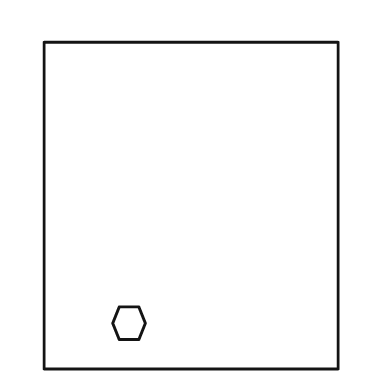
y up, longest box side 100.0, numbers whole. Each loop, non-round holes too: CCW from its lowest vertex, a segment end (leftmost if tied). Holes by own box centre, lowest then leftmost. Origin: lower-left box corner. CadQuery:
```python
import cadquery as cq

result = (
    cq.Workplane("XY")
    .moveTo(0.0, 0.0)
    .lineTo(90.0, 0.0)
    .lineTo(90.0, 100.0)
    .lineTo(0.0, 100.0)
    .close()
    .moveTo(23.0, 9.0)
    .lineTo(29.0, 9.0)
    .lineTo(31.0, 14.0)
    .lineTo(29.0, 19.0)
    .lineTo(23.0, 19.0)
    .lineTo(21.0, 14.0)
    .close()
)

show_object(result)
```